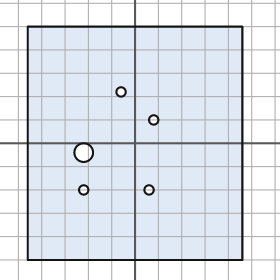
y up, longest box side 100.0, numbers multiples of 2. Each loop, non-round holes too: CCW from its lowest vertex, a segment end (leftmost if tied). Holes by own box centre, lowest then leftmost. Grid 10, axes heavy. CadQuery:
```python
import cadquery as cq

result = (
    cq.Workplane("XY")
    .moveTo(-46.0, -50.0)
    .lineTo(46.0, -50.0)
    .lineTo(46.0, 50.0)
    .lineTo(-46.0, 50.0)
    .close()
    .moveTo(-22.0, -20.0)
    .circle(2.0)
    .moveTo(6.0, -20.0)
    .circle(2.0)
    .moveTo(-22.0, -4.0)
    .circle(4.0)
    .moveTo(8.0, 10.0)
    .circle(2.0)
    .moveTo(-6.0, 22.0)
    .circle(2.0)
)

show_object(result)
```